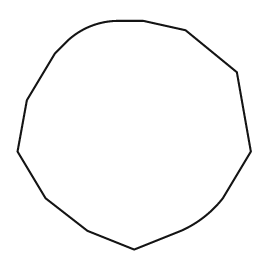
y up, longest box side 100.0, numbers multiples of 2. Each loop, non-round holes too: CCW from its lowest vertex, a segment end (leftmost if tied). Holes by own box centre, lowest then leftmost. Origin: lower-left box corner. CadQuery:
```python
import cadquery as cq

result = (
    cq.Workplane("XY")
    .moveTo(50.0, 0.0)
    .lineTo(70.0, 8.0)
    .threePointArc((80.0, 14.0), (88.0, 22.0))
    .lineTo(100.0, 42.0)
    .lineTo(94.0, 76.0)
    .lineTo(72.0, 94.0)
    .lineTo(54.0, 98.0)
    .lineTo(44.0, 98.0)
    .threePointArc((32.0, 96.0), (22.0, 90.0))
    .lineTo(16.0, 84.0)
    .lineTo(4.0, 64.0)
    .lineTo(0.0, 42.0)
    .lineTo(12.0, 22.0)
    .lineTo(30.0, 8.0)
    .close()
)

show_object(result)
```